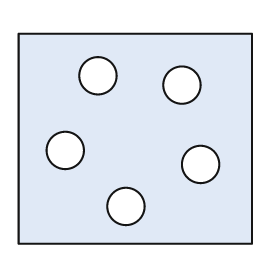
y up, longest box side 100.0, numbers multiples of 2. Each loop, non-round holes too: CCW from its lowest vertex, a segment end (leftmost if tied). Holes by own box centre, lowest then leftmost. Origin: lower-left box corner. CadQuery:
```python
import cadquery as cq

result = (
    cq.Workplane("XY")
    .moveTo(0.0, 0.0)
    .lineTo(100.0, 0.0)
    .lineTo(100.0, 90.0)
    .lineTo(0.0, 90.0)
    .close()
    .moveTo(46.0, 16.0)
    .circle(8.0)
    .moveTo(78.0, 34.0)
    .circle(8.0)
    .moveTo(20.0, 40.0)
    .circle(8.0)
    .moveTo(70.0, 68.0)
    .circle(8.0)
    .moveTo(34.0, 72.0)
    .circle(8.0)
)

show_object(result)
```